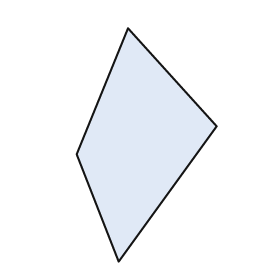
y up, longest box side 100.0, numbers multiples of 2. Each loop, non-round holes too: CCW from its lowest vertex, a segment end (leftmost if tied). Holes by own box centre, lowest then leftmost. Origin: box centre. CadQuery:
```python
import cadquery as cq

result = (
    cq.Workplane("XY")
    .moveTo(-12.0, -50.0)
    .lineTo(30.0, 8.0)
    .lineTo(-8.0, 50.0)
    .lineTo(-30.0, -4.0)
    .close()
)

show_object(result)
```